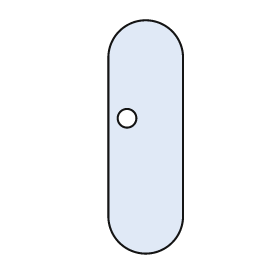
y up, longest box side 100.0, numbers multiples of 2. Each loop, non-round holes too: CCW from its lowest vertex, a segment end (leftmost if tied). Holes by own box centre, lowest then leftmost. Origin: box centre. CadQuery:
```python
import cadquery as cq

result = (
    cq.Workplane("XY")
    .moveTo(-16.0, -34.0)
    .threePointArc((0.0, -50.0), (16.0, -34.0))
    .lineTo(16.0, 34.0)
    .threePointArc((0.0, 50.0), (-16.0, 34.0))
    .close()
    .moveTo(-8.0, 8.0)
    .circle(4.0)
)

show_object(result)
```